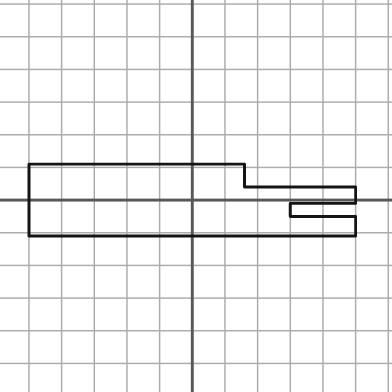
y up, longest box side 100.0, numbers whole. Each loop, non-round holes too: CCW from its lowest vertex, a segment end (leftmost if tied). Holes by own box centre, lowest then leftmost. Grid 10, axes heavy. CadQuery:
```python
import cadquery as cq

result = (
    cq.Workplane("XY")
    .moveTo(-50.0, -11.0)
    .lineTo(50.0, -11.0)
    .lineTo(50.0, -5.0)
    .lineTo(30.0, -5.0)
    .lineTo(30.0, -1.0)
    .lineTo(50.0, -1.0)
    .lineTo(50.0, 4.0)
    .lineTo(16.0, 4.0)
    .lineTo(16.0, 11.0)
    .lineTo(-50.0, 11.0)
    .close()
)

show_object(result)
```